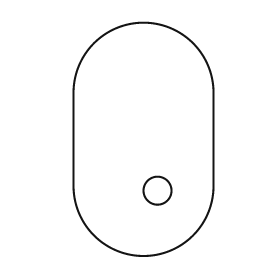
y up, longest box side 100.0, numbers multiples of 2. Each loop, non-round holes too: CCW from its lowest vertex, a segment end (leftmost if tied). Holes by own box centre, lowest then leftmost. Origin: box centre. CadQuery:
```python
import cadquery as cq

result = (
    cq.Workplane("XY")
    .moveTo(-30.0, -20.0)
    .threePointArc((0.0, -50.0), (30.0, -20.0))
    .lineTo(30.0, 20.0)
    .threePointArc((0.0, 50.0), (-30.0, 20.0))
    .close()
    .moveTo(6.0, -22.0)
    .circle(6.0)
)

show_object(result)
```